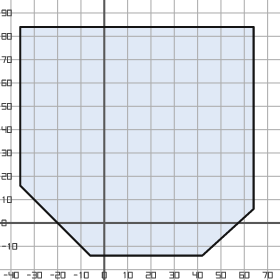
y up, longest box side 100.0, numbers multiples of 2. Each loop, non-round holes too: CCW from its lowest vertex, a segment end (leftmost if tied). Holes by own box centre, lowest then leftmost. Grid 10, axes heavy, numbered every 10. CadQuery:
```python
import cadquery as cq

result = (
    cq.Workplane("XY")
    .moveTo(-6.0, -14.0)
    .lineTo(42.0, -14.0)
    .lineTo(64.0, 6.0)
    .lineTo(64.0, 84.0)
    .lineTo(-36.0, 84.0)
    .lineTo(-36.0, 16.0)
    .close()
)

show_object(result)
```